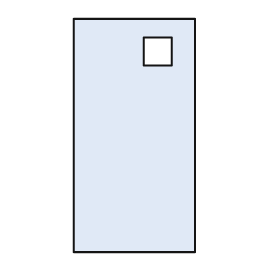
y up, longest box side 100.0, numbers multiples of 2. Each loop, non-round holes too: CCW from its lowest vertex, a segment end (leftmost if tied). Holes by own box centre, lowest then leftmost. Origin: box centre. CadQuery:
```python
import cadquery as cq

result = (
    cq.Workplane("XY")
    .moveTo(-26.0, -50.0)
    .lineTo(26.0, -50.0)
    .lineTo(26.0, 50.0)
    .lineTo(-26.0, 50.0)
    .close()
    .moveTo(4.0, 30.0)
    .lineTo(16.0, 30.0)
    .lineTo(16.0, 42.0)
    .lineTo(4.0, 42.0)
    .close()
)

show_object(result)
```